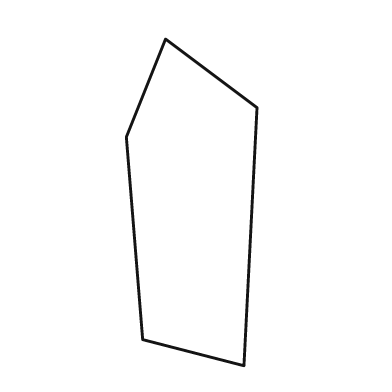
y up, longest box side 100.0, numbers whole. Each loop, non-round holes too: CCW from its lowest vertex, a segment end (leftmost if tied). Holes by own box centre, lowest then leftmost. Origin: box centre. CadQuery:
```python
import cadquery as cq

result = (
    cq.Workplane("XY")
    .moveTo(16.0, -50.0)
    .lineTo(20.0, 29.0)
    .lineTo(-8.0, 50.0)
    .lineTo(-20.0, 20.0)
    .lineTo(-15.0, -42.0)
    .close()
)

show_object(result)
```